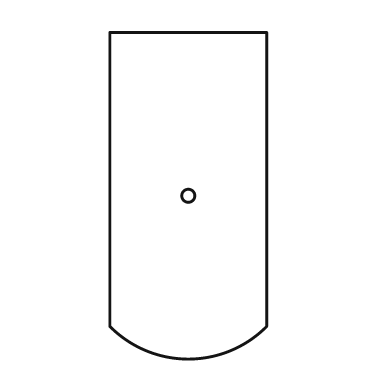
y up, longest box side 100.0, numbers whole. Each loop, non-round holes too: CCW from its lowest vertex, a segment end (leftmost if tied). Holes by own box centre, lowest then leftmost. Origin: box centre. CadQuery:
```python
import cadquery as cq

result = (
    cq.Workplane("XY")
    .moveTo(-24.0, -40.0)
    .threePointArc((0.0, -50.0), (24.0, -40.0))
    .lineTo(24.0, 50.0)
    .lineTo(-24.0, 50.0)
    .close()
    .moveTo(0.0, 0.0)
    .circle(2.0)
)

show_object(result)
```